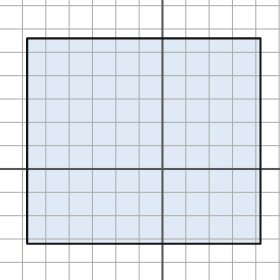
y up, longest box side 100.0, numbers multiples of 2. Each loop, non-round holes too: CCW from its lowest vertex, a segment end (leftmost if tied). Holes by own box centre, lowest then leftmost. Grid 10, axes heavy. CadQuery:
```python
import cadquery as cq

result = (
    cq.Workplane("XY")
    .moveTo(-58.0, -32.0)
    .lineTo(42.0, -32.0)
    .lineTo(42.0, 56.0)
    .lineTo(-58.0, 56.0)
    .close()
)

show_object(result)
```